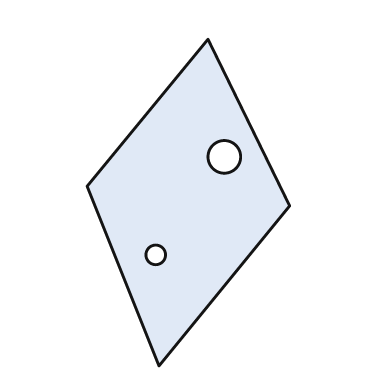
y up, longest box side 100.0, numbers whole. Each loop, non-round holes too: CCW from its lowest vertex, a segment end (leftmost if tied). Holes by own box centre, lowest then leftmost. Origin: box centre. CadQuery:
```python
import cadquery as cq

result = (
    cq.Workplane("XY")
    .moveTo(-9.0, -50.0)
    .lineTo(31.0, -1.0)
    .lineTo(6.0, 50.0)
    .lineTo(-31.0, 5.0)
    .close()
    .moveTo(-10.0, -16.0)
    .circle(3.0)
    .moveTo(11.0, 14.0)
    .circle(5.0)
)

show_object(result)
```